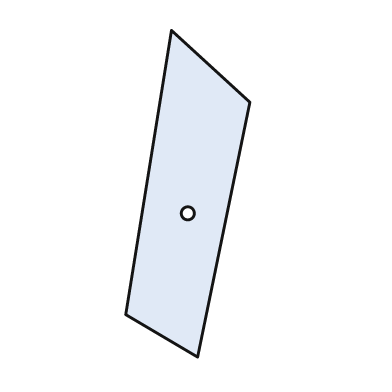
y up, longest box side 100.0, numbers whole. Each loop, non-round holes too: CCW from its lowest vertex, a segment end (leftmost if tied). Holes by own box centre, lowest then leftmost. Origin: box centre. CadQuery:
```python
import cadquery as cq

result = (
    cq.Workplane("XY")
    .moveTo(3.0, -50.0)
    .lineTo(19.0, 28.0)
    .lineTo(-5.0, 50.0)
    .lineTo(-19.0, -37.0)
    .close()
    .moveTo(0.0, -6.0)
    .circle(2.0)
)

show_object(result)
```